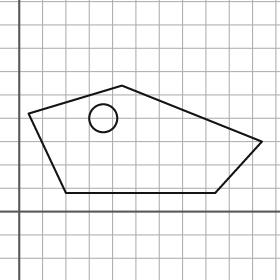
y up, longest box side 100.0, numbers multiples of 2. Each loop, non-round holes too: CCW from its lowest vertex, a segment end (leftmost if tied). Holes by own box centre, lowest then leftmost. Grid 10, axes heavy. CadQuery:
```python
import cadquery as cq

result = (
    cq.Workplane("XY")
    .moveTo(20.0, 8.0)
    .lineTo(84.0, 8.0)
    .lineTo(104.0, 30.0)
    .lineTo(44.0, 54.0)
    .lineTo(4.0, 42.0)
    .close()
    .moveTo(36.0, 40.0)
    .circle(6.0)
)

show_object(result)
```